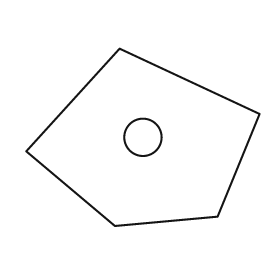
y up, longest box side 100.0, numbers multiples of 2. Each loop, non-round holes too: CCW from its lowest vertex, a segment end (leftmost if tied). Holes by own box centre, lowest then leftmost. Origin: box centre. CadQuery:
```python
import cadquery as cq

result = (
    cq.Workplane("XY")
    .moveTo(-12.0, -38.0)
    .lineTo(32.0, -34.0)
    .lineTo(50.0, 10.0)
    .lineTo(-10.0, 38.0)
    .lineTo(-50.0, -6.0)
    .close()
    .moveTo(0.0, 0.0)
    .circle(8.0)
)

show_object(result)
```